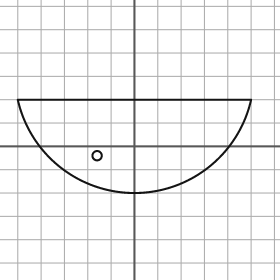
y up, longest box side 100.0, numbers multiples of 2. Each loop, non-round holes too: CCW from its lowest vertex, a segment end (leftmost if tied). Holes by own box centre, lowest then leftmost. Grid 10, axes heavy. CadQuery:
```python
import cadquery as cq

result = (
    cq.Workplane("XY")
    .moveTo(-50.0, 20.0)
    .threePointArc((0.0, -20.0), (50.0, 20.0))
    .close()
    .moveTo(-16.0, -4.0)
    .circle(2.0)
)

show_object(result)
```